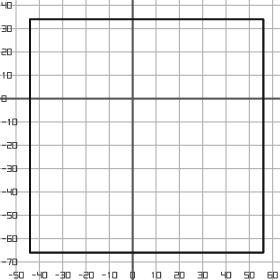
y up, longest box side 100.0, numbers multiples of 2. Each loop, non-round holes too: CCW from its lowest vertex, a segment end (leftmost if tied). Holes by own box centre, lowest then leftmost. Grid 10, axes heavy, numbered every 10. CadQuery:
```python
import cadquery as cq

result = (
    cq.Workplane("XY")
    .moveTo(-44.0, -66.0)
    .lineTo(56.0, -66.0)
    .lineTo(56.0, 34.0)
    .lineTo(-44.0, 34.0)
    .close()
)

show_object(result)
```